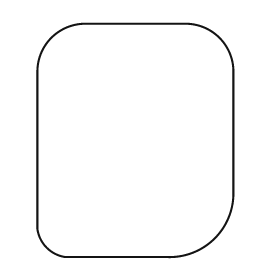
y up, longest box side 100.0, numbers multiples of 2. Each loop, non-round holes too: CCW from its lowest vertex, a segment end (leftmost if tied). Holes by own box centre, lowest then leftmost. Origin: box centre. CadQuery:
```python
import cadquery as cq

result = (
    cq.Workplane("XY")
    .moveTo(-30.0, -50.0)
    .lineTo(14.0, -50.0)
    .threePointArc((34.0, -42.0), (42.0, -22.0))
    .lineTo(42.0, 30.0)
    .threePointArc((36.0, 44.0), (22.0, 50.0))
    .lineTo(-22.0, 50.0)
    .threePointArc((-36.0, 44.0), (-42.0, 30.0))
    .lineTo(-42.0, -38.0)
    .threePointArc((-38.0, -46.0), (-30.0, -50.0))
    .close()
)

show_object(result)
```